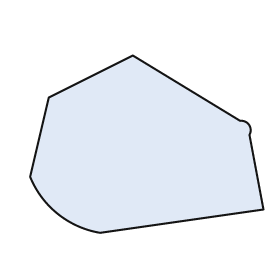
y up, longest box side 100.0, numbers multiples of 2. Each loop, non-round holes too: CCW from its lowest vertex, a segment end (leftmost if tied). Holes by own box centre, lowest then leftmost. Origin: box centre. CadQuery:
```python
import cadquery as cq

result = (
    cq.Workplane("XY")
    .moveTo(-20.0, -38.0)
    .lineTo(50.0, -28.0)
    .lineTo(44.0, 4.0)
    .threePointArc((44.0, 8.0), (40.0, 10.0))
    .lineTo(-6.0, 38.0)
    .lineTo(-42.0, 20.0)
    .lineTo(-50.0, -14.0)
    .threePointArc((-38.0, -30.0), (-20.0, -38.0))
    .close()
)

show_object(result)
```